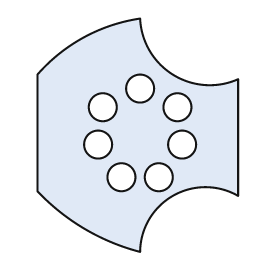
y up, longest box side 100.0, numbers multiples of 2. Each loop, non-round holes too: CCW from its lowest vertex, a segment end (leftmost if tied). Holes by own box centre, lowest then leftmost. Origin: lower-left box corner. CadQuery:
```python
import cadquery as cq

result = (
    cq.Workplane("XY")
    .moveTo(44.0, 0.0)
    .threePointArc((58.0, 24.0), (86.0, 24.0))
    .lineTo(86.0, 74.0)
    .threePointArc((58.0, 76.0), (44.0, 100.0))
    .threePointArc((20.0, 92.0), (0.0, 76.0))
    .lineTo(0.0, 26.0)
    .threePointArc((20.0, 10.0), (44.0, 0.0))
    .close()
    .moveTo(36.0, 32.0)
    .circle(6.0)
    .moveTo(52.0, 32.0)
    .circle(6.0)
    .moveTo(26.0, 46.0)
    .circle(6.0)
    .moveTo(62.0, 46.0)
    .circle(6.0)
    .moveTo(28.0, 62.0)
    .circle(6.0)
    .moveTo(60.0, 62.0)
    .circle(6.0)
    .moveTo(44.0, 70.0)
    .circle(6.0)
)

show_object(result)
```